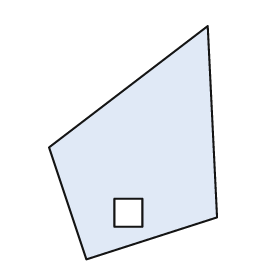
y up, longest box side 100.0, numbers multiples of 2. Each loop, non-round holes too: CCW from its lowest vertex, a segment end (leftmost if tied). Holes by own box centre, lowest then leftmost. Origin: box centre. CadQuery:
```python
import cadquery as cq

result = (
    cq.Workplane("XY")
    .moveTo(-20.0, -50.0)
    .lineTo(36.0, -32.0)
    .lineTo(32.0, 50.0)
    .lineTo(-36.0, -2.0)
    .close()
    .moveTo(-8.0, -36.0)
    .lineTo(4.0, -36.0)
    .lineTo(4.0, -24.0)
    .lineTo(-8.0, -24.0)
    .close()
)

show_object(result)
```